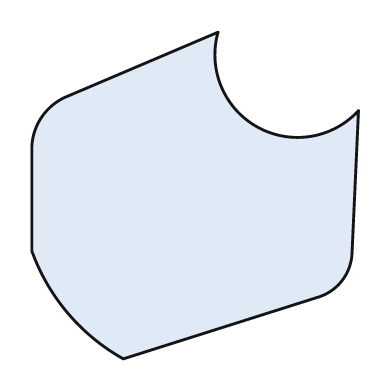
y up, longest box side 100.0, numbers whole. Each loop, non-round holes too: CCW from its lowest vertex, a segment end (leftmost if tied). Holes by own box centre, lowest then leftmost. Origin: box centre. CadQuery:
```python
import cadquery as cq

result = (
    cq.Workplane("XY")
    .moveTo(-22.0, -50.0)
    .lineTo(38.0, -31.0)
    .threePointArc((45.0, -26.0), (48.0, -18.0))
    .lineTo(50.0, 26.0)
    .threePointArc((19.0, 21.0), (7.0, 50.0))
    .lineTo(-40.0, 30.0)
    .threePointArc((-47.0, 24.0), (-50.0, 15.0))
    .lineTo(-50.0, -17.0)
    .threePointArc((-39.0, -36.0), (-22.0, -50.0))
    .close()
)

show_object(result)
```